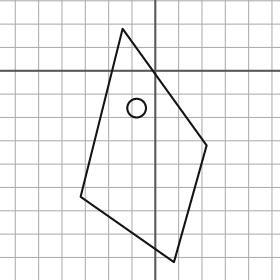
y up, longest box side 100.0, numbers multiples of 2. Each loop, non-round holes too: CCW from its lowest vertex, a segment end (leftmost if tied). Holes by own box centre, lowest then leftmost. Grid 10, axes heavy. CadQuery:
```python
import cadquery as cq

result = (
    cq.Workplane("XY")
    .moveTo(8.0, -82.0)
    .lineTo(22.0, -32.0)
    .lineTo(-14.0, 18.0)
    .lineTo(-32.0, -54.0)
    .close()
    .moveTo(-8.0, -16.0)
    .circle(4.0)
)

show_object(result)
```